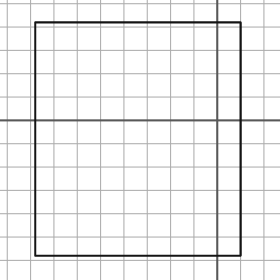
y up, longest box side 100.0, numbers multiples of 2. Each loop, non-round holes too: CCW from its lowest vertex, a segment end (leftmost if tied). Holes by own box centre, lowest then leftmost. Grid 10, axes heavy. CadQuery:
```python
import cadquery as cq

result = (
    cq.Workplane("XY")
    .moveTo(-78.0, -58.0)
    .lineTo(10.0, -58.0)
    .lineTo(10.0, 42.0)
    .lineTo(-78.0, 42.0)
    .close()
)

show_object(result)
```